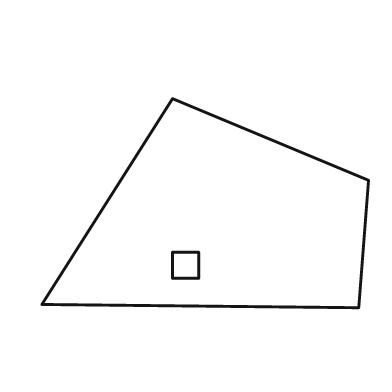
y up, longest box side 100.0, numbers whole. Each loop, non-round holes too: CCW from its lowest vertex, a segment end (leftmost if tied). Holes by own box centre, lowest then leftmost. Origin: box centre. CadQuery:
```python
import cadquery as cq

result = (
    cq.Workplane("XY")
    .moveTo(47.0, -32.0)
    .lineTo(50.0, 7.0)
    .lineTo(-10.0, 32.0)
    .lineTo(-50.0, -31.0)
    .close()
    .moveTo(-10.0, -23.0)
    .lineTo(-2.0, -23.0)
    .lineTo(-2.0, -15.0)
    .lineTo(-10.0, -15.0)
    .close()
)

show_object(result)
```